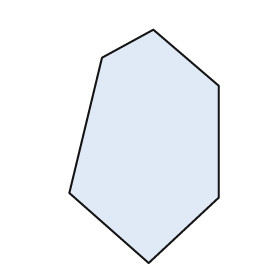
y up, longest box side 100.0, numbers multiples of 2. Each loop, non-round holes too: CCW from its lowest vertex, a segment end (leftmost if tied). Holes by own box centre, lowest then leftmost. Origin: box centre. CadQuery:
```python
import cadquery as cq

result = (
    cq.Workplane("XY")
    .moveTo(2.0, -50.0)
    .lineTo(32.0, -22.0)
    .lineTo(32.0, 26.0)
    .lineTo(4.0, 50.0)
    .lineTo(-18.0, 38.0)
    .lineTo(-32.0, -20.0)
    .close()
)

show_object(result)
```